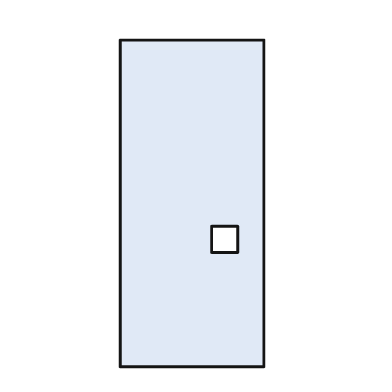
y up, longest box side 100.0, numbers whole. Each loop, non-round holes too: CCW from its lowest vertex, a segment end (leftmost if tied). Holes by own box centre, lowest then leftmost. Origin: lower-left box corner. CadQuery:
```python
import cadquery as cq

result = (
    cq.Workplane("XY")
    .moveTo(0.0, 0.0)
    .lineTo(44.0, 0.0)
    .lineTo(44.0, 100.0)
    .lineTo(0.0, 100.0)
    .close()
    .moveTo(28.0, 35.0)
    .lineTo(36.0, 35.0)
    .lineTo(36.0, 43.0)
    .lineTo(28.0, 43.0)
    .close()
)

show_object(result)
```